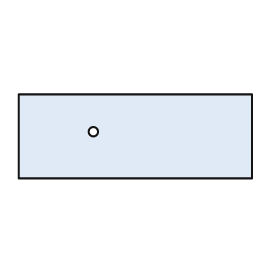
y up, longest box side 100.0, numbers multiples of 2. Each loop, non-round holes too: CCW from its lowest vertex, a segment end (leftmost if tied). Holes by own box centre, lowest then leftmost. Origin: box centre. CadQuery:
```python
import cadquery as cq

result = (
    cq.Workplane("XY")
    .moveTo(-50.0, -18.0)
    .lineTo(50.0, -18.0)
    .lineTo(50.0, 18.0)
    .lineTo(-50.0, 18.0)
    .close()
    .moveTo(-18.0, 2.0)
    .circle(2.0)
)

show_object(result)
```